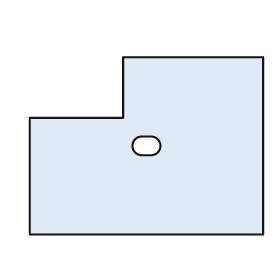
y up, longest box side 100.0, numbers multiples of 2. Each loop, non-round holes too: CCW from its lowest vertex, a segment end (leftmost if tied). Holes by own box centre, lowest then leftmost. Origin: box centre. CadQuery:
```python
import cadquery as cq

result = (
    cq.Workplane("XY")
    .moveTo(-50.0, -38.0)
    .lineTo(50.0, -38.0)
    .lineTo(50.0, 38.0)
    .lineTo(-10.0, 38.0)
    .lineTo(-10.0, 12.0)
    .lineTo(-50.0, 12.0)
    .close()
    .moveTo(-2.0, -4.0)
    .lineTo(2.0, -4.0)
    .threePointArc((6.0, 0.0), (2.0, 4.0))
    .lineTo(-2.0, 4.0)
    .threePointArc((-6.0, 0.0), (-2.0, -4.0))
    .close()
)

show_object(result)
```